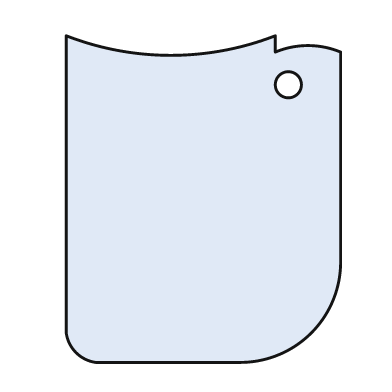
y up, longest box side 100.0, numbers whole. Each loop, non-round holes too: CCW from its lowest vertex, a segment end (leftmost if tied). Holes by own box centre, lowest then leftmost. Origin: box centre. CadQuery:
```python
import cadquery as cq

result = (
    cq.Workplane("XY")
    .moveTo(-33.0, -50.0)
    .lineTo(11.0, -50.0)
    .threePointArc((33.0, -41.0), (42.0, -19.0))
    .lineTo(42.0, 45.0)
    .threePointArc((32.0, 47.0), (22.0, 45.0))
    .lineTo(22.0, 50.0)
    .threePointArc((-10.0, 44.0), (-42.0, 50.0))
    .lineTo(-42.0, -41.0)
    .threePointArc((-39.0, -47.0), (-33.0, -50.0))
    .close()
    .moveTo(26.0, 35.0)
    .circle(4.0)
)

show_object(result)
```